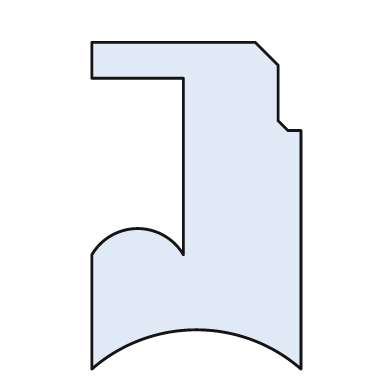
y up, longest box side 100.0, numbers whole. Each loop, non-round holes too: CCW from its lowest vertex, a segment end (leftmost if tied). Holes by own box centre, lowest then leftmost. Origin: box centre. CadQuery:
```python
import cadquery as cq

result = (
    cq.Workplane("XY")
    .moveTo(-32.0, -50.0)
    .threePointArc((0.0, -38.0), (32.0, -50.0))
    .lineTo(32.0, 23.0)
    .lineTo(28.0, 23.0)
    .lineTo(25.0, 26.0)
    .lineTo(25.0, 43.0)
    .lineTo(18.0, 50.0)
    .lineTo(-32.0, 50.0)
    .lineTo(-32.0, 39.0)
    .lineTo(-4.0, 39.0)
    .lineTo(-4.0, -15.0)
    .threePointArc((-18.0, -7.0), (-32.0, -15.0))
    .close()
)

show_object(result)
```